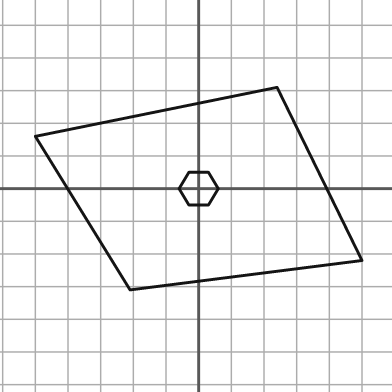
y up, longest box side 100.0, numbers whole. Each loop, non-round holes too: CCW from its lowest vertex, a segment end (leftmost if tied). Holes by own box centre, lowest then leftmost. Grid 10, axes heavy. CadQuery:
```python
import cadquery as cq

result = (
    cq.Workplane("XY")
    .moveTo(-21.0, -31.0)
    .lineTo(50.0, -22.0)
    .lineTo(24.0, 31.0)
    .lineTo(-50.0, 16.0)
    .close()
    .moveTo(-3.0, -5.0)
    .lineTo(3.0, -5.0)
    .lineTo(6.0, 0.0)
    .lineTo(3.0, 5.0)
    .lineTo(-3.0, 5.0)
    .lineTo(-6.0, 0.0)
    .close()
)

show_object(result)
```